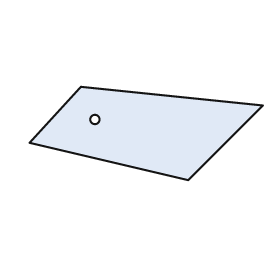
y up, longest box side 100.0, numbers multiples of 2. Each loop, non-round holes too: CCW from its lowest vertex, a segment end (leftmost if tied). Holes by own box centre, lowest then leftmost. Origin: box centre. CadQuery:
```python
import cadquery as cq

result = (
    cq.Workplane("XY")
    .moveTo(18.0, -20.0)
    .lineTo(50.0, 12.0)
    .lineTo(-28.0, 20.0)
    .lineTo(-50.0, -4.0)
    .close()
    .moveTo(-22.0, 6.0)
    .circle(2.0)
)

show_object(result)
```